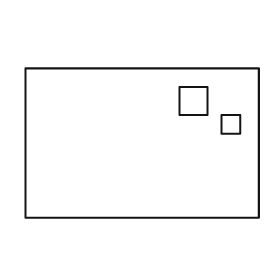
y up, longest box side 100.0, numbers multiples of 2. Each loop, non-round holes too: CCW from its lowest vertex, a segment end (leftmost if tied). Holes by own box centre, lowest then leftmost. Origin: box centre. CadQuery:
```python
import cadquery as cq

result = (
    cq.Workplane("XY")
    .moveTo(-50.0, -32.0)
    .lineTo(50.0, -32.0)
    .lineTo(50.0, 32.0)
    .lineTo(-50.0, 32.0)
    .close()
    .moveTo(34.0, 4.0)
    .lineTo(42.0, 4.0)
    .lineTo(42.0, 12.0)
    .lineTo(34.0, 12.0)
    .close()
    .moveTo(16.0, 12.0)
    .lineTo(28.0, 12.0)
    .lineTo(28.0, 24.0)
    .lineTo(16.0, 24.0)
    .close()
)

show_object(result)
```